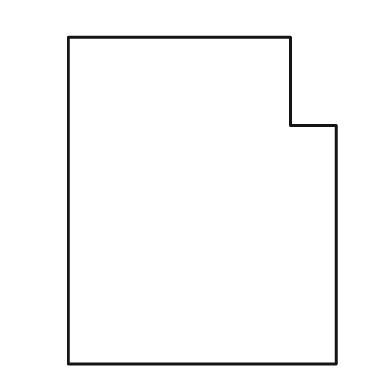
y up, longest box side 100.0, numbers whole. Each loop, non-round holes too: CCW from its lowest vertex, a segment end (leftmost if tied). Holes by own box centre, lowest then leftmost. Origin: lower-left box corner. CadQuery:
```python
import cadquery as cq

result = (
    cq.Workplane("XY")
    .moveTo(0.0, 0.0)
    .lineTo(82.0, 0.0)
    .lineTo(82.0, 73.0)
    .lineTo(68.0, 73.0)
    .lineTo(68.0, 100.0)
    .lineTo(0.0, 100.0)
    .close()
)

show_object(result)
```